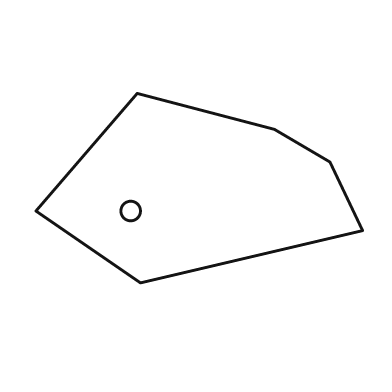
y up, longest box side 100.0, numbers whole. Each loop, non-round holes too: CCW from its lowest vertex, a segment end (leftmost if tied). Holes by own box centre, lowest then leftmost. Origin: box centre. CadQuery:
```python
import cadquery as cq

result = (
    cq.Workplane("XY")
    .moveTo(-18.0, -29.0)
    .lineTo(50.0, -13.0)
    .lineTo(40.0, 8.0)
    .lineTo(23.0, 18.0)
    .lineTo(-19.0, 29.0)
    .lineTo(-50.0, -7.0)
    .close()
    .moveTo(-21.0, -7.0)
    .circle(3.0)
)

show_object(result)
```